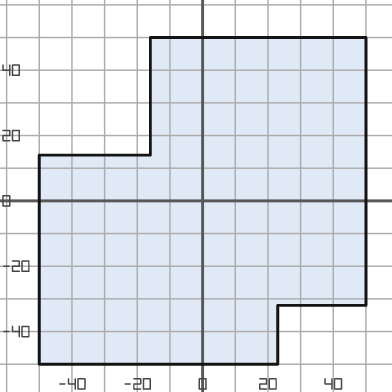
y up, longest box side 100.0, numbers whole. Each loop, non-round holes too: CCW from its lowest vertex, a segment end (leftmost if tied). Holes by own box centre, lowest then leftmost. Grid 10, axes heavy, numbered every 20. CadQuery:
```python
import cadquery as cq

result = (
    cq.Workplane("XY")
    .moveTo(-50.0, -50.0)
    .lineTo(23.0, -50.0)
    .lineTo(23.0, -32.0)
    .lineTo(50.0, -32.0)
    .lineTo(50.0, 50.0)
    .lineTo(-16.0, 50.0)
    .lineTo(-16.0, 14.0)
    .lineTo(-50.0, 14.0)
    .close()
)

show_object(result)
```